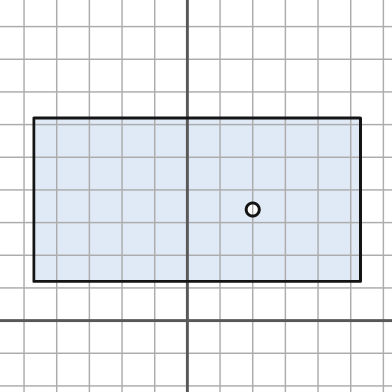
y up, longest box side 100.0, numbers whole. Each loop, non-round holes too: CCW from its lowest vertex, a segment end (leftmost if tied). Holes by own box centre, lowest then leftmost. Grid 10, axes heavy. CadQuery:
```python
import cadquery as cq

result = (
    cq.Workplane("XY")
    .moveTo(-47.0, 12.0)
    .lineTo(53.0, 12.0)
    .lineTo(53.0, 62.0)
    .lineTo(-47.0, 62.0)
    .close()
    .moveTo(20.0, 34.0)
    .circle(2.0)
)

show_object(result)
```